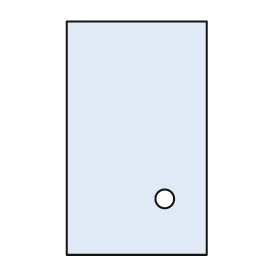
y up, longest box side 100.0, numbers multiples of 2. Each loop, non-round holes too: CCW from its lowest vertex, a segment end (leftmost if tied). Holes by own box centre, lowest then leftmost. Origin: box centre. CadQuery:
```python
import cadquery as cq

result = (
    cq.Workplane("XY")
    .moveTo(-30.0, -50.0)
    .lineTo(30.0, -50.0)
    .lineTo(30.0, 50.0)
    .lineTo(-30.0, 50.0)
    .close()
    .moveTo(12.0, -26.0)
    .circle(4.0)
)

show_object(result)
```